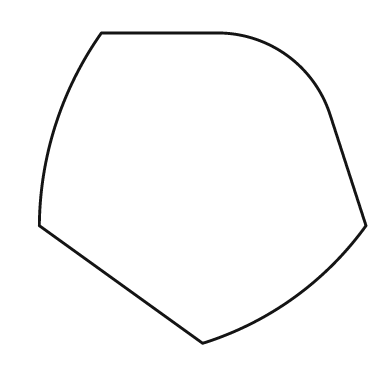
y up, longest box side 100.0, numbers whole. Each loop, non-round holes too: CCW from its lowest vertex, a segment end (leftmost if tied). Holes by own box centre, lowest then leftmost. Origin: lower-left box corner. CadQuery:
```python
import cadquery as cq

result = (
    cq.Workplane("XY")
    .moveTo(50.0, 0.0)
    .threePointArc((78.0, 14.0), (100.0, 36.0))
    .lineTo(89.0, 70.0)
    .threePointArc((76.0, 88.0), (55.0, 95.0))
    .lineTo(19.0, 95.0)
    .threePointArc((5.0, 67.0), (0.0, 36.0))
    .close()
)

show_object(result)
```